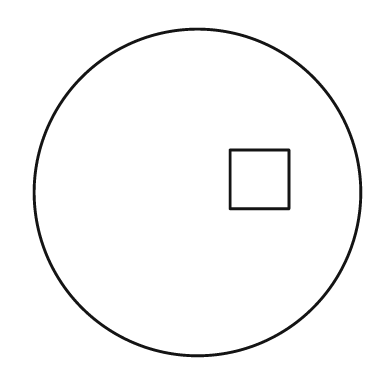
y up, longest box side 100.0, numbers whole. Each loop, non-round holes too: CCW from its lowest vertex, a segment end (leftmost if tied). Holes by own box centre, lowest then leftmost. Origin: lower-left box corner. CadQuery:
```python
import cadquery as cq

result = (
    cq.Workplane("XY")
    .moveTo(50.0, 50.0)
    .circle(50.0)
    .moveTo(60.0, 45.0)
    .lineTo(78.0, 45.0)
    .lineTo(78.0, 63.0)
    .lineTo(60.0, 63.0)
    .close()
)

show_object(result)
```